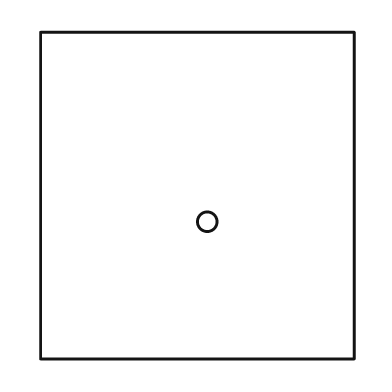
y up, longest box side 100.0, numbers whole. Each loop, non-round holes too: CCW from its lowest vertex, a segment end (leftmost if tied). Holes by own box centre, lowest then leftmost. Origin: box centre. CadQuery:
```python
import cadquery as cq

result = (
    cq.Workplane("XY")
    .moveTo(-48.0, -50.0)
    .lineTo(48.0, -50.0)
    .lineTo(48.0, 50.0)
    .lineTo(-48.0, 50.0)
    .close()
    .moveTo(3.0, -8.0)
    .circle(3.0)
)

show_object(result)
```